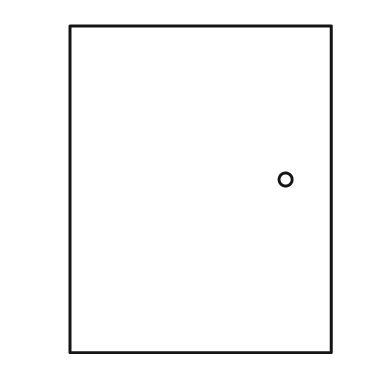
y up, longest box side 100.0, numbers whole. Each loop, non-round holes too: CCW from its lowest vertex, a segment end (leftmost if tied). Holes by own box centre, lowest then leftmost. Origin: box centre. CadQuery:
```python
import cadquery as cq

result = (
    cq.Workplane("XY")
    .moveTo(-40.0, -50.0)
    .lineTo(40.0, -50.0)
    .lineTo(40.0, 50.0)
    .lineTo(-40.0, 50.0)
    .close()
    .moveTo(26.0, 3.0)
    .circle(2.0)
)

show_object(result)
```